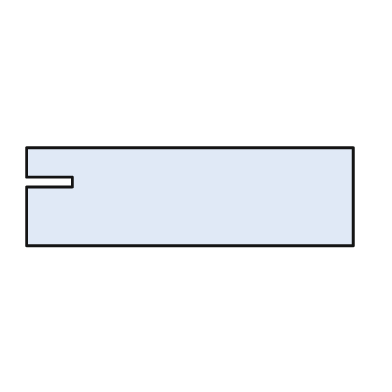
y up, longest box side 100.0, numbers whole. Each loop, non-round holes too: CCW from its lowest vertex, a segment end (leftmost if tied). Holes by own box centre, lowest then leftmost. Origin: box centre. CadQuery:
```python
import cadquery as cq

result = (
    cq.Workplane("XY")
    .moveTo(-50.0, -15.0)
    .lineTo(50.0, -15.0)
    .lineTo(50.0, 15.0)
    .lineTo(-50.0, 15.0)
    .lineTo(-50.0, 6.0)
    .lineTo(-36.0, 6.0)
    .lineTo(-36.0, 3.0)
    .lineTo(-50.0, 3.0)
    .close()
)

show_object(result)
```